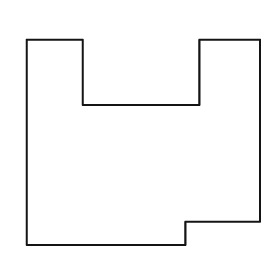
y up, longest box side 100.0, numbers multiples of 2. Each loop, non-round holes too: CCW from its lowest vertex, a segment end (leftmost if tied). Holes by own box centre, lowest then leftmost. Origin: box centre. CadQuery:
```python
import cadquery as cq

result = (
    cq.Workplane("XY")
    .moveTo(-50.0, -44.0)
    .lineTo(18.0, -44.0)
    .lineTo(18.0, -34.0)
    .lineTo(50.0, -34.0)
    .lineTo(50.0, 44.0)
    .lineTo(24.0, 44.0)
    .lineTo(24.0, 16.0)
    .lineTo(-26.0, 16.0)
    .lineTo(-26.0, 44.0)
    .lineTo(-50.0, 44.0)
    .close()
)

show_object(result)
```